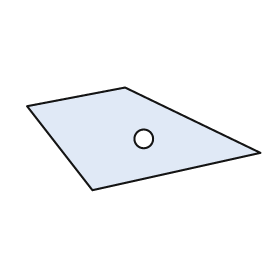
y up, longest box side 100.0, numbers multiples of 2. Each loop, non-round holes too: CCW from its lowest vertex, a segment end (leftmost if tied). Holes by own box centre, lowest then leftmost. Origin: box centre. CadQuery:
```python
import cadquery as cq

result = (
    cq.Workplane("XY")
    .moveTo(-22.0, -22.0)
    .lineTo(50.0, -6.0)
    .lineTo(-8.0, 22.0)
    .lineTo(-50.0, 14.0)
    .close()
    .moveTo(0.0, 0.0)
    .circle(4.0)
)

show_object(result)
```